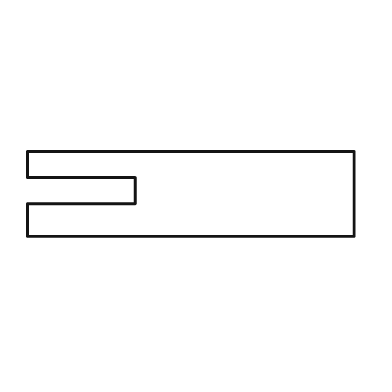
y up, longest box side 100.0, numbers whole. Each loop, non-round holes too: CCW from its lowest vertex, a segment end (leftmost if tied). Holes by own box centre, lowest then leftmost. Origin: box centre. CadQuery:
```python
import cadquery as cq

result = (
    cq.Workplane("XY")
    .moveTo(-50.0, -13.0)
    .lineTo(50.0, -13.0)
    .lineTo(50.0, 13.0)
    .lineTo(-50.0, 13.0)
    .lineTo(-50.0, 5.0)
    .lineTo(-17.0, 5.0)
    .lineTo(-17.0, -3.0)
    .lineTo(-50.0, -3.0)
    .close()
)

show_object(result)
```